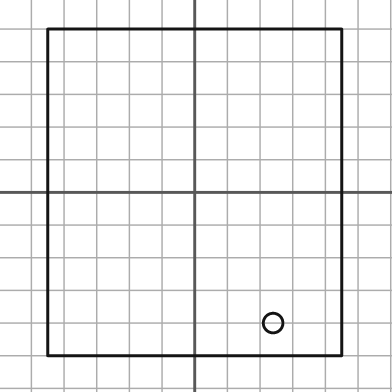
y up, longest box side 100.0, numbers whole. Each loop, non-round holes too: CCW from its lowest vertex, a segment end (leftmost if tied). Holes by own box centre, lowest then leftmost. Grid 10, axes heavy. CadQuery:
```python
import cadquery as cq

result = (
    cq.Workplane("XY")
    .moveTo(-45.0, -50.0)
    .lineTo(45.0, -50.0)
    .lineTo(45.0, 50.0)
    .lineTo(-45.0, 50.0)
    .close()
    .moveTo(24.0, -40.0)
    .circle(3.0)
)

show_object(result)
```